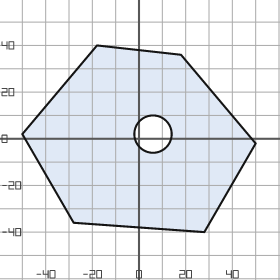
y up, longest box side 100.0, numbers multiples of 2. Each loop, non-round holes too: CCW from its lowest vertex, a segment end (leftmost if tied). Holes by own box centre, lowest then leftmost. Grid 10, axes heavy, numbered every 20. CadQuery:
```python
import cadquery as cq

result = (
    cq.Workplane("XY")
    .moveTo(28.0, -40.0)
    .lineTo(50.0, -2.0)
    .lineTo(18.0, 36.0)
    .lineTo(-18.0, 40.0)
    .lineTo(-50.0, 2.0)
    .lineTo(-28.0, -36.0)
    .close()
    .moveTo(6.0, 2.0)
    .circle(8.0)
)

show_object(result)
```